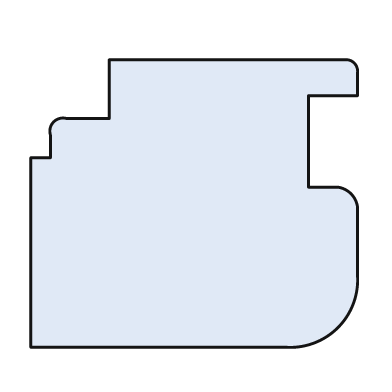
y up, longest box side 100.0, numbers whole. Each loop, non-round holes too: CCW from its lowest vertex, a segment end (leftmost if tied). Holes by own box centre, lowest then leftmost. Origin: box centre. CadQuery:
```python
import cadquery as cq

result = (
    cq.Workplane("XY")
    .moveTo(-50.0, -44.0)
    .lineTo(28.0, -44.0)
    .threePointArc((44.0, -38.0), (50.0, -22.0))
    .lineTo(50.0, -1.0)
    .threePointArc((48.0, 3.0), (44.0, 5.0))
    .lineTo(35.0, 5.0)
    .lineTo(35.0, 33.0)
    .lineTo(50.0, 33.0)
    .lineTo(50.0, 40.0)
    .threePointArc((49.0, 43.0), (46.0, 44.0))
    .lineTo(-26.0, 44.0)
    .lineTo(-26.0, 26.0)
    .lineTo(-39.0, 26.0)
    .threePointArc((-43.0, 25.0), (-44.0, 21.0))
    .lineTo(-44.0, 14.0)
    .lineTo(-50.0, 14.0)
    .close()
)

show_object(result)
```